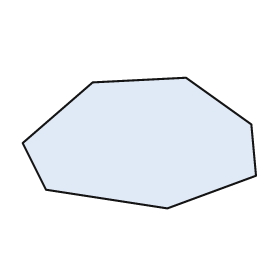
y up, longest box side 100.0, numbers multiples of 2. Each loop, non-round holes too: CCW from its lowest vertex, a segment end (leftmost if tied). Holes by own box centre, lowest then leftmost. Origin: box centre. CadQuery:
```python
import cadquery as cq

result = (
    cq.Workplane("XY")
    .moveTo(12.0, -28.0)
    .lineTo(50.0, -14.0)
    .lineTo(48.0, 8.0)
    .lineTo(20.0, 28.0)
    .lineTo(-20.0, 26.0)
    .lineTo(-50.0, 0.0)
    .lineTo(-40.0, -20.0)
    .close()
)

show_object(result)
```